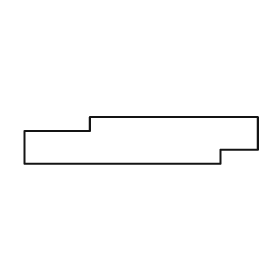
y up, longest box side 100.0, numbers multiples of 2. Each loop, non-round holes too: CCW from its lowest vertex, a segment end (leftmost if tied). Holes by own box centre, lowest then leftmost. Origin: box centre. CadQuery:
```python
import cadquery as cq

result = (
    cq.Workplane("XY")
    .moveTo(-50.0, -10.0)
    .lineTo(34.0, -10.0)
    .lineTo(34.0, -4.0)
    .lineTo(50.0, -4.0)
    .lineTo(50.0, 10.0)
    .lineTo(-22.0, 10.0)
    .lineTo(-22.0, 4.0)
    .lineTo(-50.0, 4.0)
    .close()
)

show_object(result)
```